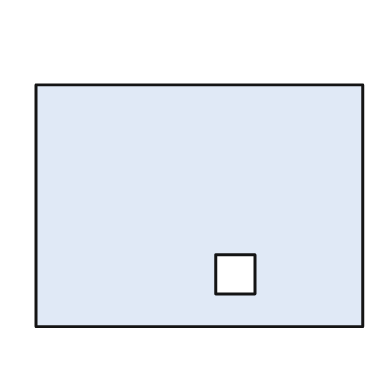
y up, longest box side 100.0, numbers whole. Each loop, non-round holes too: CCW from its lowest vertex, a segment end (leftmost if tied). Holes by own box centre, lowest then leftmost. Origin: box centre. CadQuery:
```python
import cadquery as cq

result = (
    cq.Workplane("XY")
    .moveTo(-50.0, -37.0)
    .lineTo(50.0, -37.0)
    .lineTo(50.0, 37.0)
    .lineTo(-50.0, 37.0)
    .close()
    .moveTo(5.0, -27.0)
    .lineTo(17.0, -27.0)
    .lineTo(17.0, -15.0)
    .lineTo(5.0, -15.0)
    .close()
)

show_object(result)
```